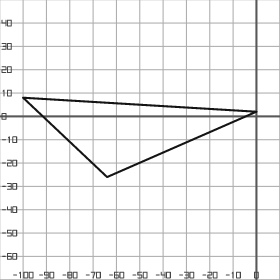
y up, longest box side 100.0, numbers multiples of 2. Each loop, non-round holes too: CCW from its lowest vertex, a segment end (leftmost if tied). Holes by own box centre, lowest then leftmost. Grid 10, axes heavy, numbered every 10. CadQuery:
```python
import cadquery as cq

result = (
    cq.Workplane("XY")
    .moveTo(-64.0, -26.0)
    .lineTo(0.0, 2.0)
    .lineTo(-100.0, 8.0)
    .close()
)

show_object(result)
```